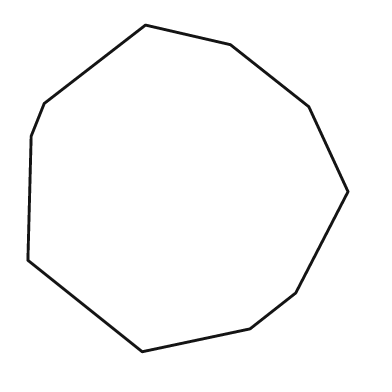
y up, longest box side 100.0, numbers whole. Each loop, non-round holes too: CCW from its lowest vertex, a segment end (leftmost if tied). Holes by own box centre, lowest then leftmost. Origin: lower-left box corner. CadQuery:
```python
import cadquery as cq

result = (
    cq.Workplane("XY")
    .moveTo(35.0, 0.0)
    .lineTo(68.0, 7.0)
    .lineTo(82.0, 18.0)
    .lineTo(98.0, 49.0)
    .lineTo(86.0, 75.0)
    .lineTo(62.0, 94.0)
    .lineTo(36.0, 100.0)
    .lineTo(5.0, 76.0)
    .lineTo(1.0, 66.0)
    .lineTo(0.0, 28.0)
    .close()
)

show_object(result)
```